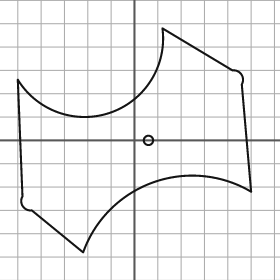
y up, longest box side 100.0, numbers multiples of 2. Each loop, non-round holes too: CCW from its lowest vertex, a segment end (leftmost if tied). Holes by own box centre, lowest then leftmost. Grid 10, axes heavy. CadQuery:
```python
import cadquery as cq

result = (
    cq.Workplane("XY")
    .moveTo(-22.0, -48.0)
    .threePointArc((8.0, -18.0), (50.0, -22.0))
    .lineTo(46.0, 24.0)
    .threePointArc((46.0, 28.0), (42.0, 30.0))
    .lineTo(12.0, 48.0)
    .threePointArc((-10.0, 12.0), (-50.0, 26.0))
    .lineTo(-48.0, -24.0)
    .threePointArc((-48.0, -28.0), (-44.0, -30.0))
    .close()
    .moveTo(6.0, 0.0)
    .circle(2.0)
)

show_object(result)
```